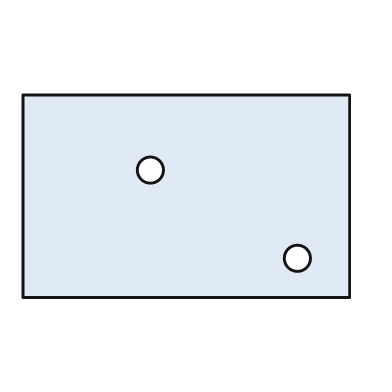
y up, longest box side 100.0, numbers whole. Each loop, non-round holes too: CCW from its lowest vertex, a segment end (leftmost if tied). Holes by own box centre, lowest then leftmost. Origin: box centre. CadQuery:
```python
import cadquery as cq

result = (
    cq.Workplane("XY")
    .moveTo(-50.0, -31.0)
    .lineTo(50.0, -31.0)
    .lineTo(50.0, 31.0)
    .lineTo(-50.0, 31.0)
    .close()
    .moveTo(34.0, -19.0)
    .circle(4.0)
    .moveTo(-11.0, 8.0)
    .circle(4.0)
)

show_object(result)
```